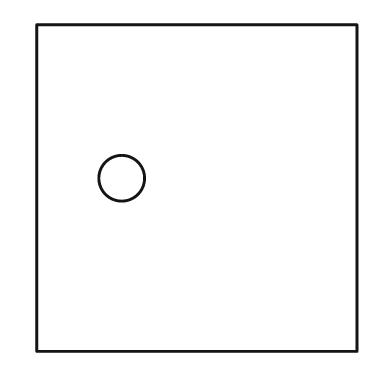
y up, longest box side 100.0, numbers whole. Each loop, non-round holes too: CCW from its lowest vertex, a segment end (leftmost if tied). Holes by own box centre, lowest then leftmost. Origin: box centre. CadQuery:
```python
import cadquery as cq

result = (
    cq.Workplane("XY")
    .moveTo(-49.0, -50.0)
    .lineTo(49.0, -50.0)
    .lineTo(49.0, 50.0)
    .lineTo(-49.0, 50.0)
    .close()
    .moveTo(-23.0, 3.0)
    .circle(7.0)
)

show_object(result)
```